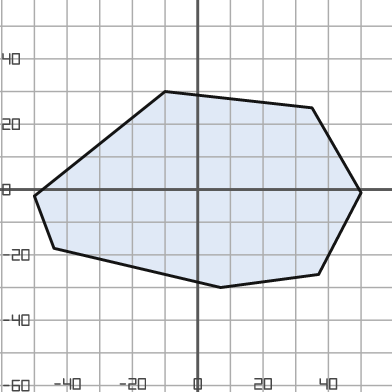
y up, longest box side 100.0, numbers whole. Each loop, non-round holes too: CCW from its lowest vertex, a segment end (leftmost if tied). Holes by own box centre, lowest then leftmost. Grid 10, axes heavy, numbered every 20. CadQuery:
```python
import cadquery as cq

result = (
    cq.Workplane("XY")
    .moveTo(7.0, -30.0)
    .lineTo(37.0, -26.0)
    .lineTo(50.0, -1.0)
    .lineTo(35.0, 25.0)
    .lineTo(-10.0, 30.0)
    .lineTo(-50.0, -2.0)
    .lineTo(-44.0, -18.0)
    .close()
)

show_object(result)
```